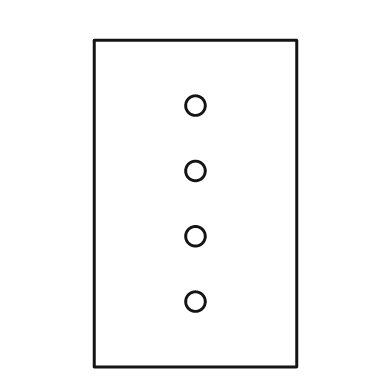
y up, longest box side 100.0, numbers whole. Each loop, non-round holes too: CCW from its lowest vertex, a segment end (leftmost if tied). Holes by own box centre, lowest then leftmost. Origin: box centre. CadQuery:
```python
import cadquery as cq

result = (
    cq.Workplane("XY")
    .moveTo(-31.0, -50.0)
    .lineTo(31.0, -50.0)
    .lineTo(31.0, 50.0)
    .lineTo(-31.0, 50.0)
    .close()
    .moveTo(0.0, -30.0)
    .circle(3.0)
    .moveTo(0.0, -10.0)
    .circle(3.0)
    .moveTo(0.0, 10.0)
    .circle(3.0)
    .moveTo(0.0, 30.0)
    .circle(3.0)
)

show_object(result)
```